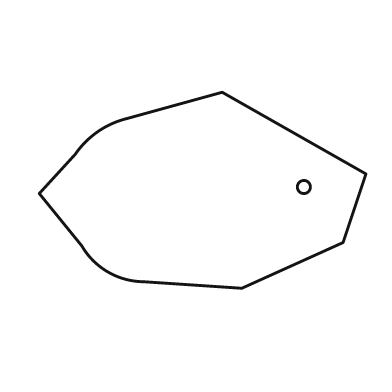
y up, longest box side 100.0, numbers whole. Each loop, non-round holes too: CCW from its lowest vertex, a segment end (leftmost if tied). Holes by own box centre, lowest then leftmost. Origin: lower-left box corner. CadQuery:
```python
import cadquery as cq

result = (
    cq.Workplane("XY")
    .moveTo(62.0, 0.0)
    .lineTo(93.0, 14.0)
    .lineTo(100.0, 35.0)
    .lineTo(56.0, 60.0)
    .lineTo(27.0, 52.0)
    .threePointArc((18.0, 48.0), (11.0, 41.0))
    .lineTo(0.0, 29.0)
    .lineTo(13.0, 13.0)
    .threePointArc((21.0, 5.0), (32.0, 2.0))
    .close()
    .moveTo(81.0, 31.0)
    .circle(2.0)
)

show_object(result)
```